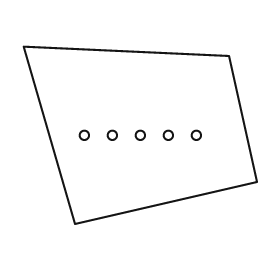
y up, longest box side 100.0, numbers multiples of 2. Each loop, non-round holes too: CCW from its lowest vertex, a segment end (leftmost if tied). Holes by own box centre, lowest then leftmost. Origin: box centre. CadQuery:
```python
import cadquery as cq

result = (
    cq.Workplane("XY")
    .moveTo(-28.0, -38.0)
    .lineTo(50.0, -20.0)
    .lineTo(38.0, 34.0)
    .lineTo(-50.0, 38.0)
    .close()
    .moveTo(-24.0, 0.0)
    .circle(2.0)
    .moveTo(-12.0, 0.0)
    .circle(2.0)
    .moveTo(0.0, 0.0)
    .circle(2.0)
    .moveTo(12.0, 0.0)
    .circle(2.0)
    .moveTo(24.0, 0.0)
    .circle(2.0)
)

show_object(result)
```